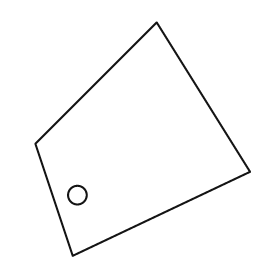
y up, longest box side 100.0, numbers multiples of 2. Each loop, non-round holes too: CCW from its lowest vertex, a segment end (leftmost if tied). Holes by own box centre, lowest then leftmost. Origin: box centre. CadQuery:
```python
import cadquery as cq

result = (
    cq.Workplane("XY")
    .moveTo(-30.0, -50.0)
    .lineTo(46.0, -14.0)
    .lineTo(6.0, 50.0)
    .lineTo(-46.0, -2.0)
    .close()
    .moveTo(-28.0, -24.0)
    .circle(4.0)
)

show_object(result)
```